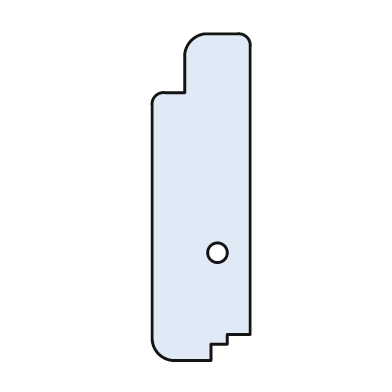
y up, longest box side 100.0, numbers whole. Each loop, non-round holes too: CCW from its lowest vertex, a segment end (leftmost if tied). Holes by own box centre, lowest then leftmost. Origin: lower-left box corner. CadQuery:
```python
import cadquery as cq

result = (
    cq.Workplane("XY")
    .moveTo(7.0, 0.0)
    .lineTo(18.0, 0.0)
    .lineTo(18.0, 5.0)
    .lineTo(23.0, 5.0)
    .lineTo(23.0, 8.0)
    .lineTo(30.0, 8.0)
    .lineTo(30.0, 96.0)
    .threePointArc((29.0, 99.0), (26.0, 100.0))
    .lineTo(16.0, 100.0)
    .threePointArc((12.0, 98.0), (10.0, 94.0))
    .lineTo(10.0, 82.0)
    .lineTo(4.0, 82.0)
    .threePointArc((1.0, 81.0), (0.0, 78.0))
    .lineTo(0.0, 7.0)
    .threePointArc((2.0, 2.0), (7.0, 0.0))
    .close()
    .moveTo(20.0, 33.0)
    .circle(3.0)
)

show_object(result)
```